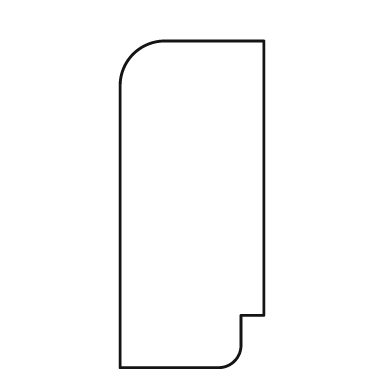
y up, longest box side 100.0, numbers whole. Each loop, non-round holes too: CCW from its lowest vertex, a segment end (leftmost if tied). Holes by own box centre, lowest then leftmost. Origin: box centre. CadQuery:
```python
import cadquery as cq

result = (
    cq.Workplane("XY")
    .moveTo(-22.0, -50.0)
    .lineTo(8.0, -50.0)
    .threePointArc((13.0, -48.0), (15.0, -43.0))
    .lineTo(15.0, -34.0)
    .lineTo(22.0, -34.0)
    .lineTo(22.0, 50.0)
    .lineTo(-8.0, 50.0)
    .threePointArc((-18.0, 46.0), (-22.0, 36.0))
    .close()
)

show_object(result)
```